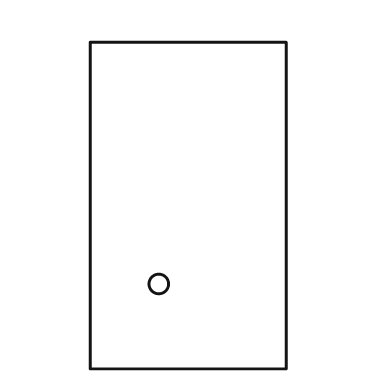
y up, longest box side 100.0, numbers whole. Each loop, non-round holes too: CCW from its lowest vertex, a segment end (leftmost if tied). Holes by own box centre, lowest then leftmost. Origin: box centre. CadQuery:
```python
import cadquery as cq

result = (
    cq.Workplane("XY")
    .moveTo(-30.0, -50.0)
    .lineTo(30.0, -50.0)
    .lineTo(30.0, 50.0)
    .lineTo(-30.0, 50.0)
    .close()
    .moveTo(-9.0, -24.0)
    .circle(3.0)
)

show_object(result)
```